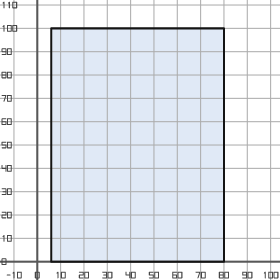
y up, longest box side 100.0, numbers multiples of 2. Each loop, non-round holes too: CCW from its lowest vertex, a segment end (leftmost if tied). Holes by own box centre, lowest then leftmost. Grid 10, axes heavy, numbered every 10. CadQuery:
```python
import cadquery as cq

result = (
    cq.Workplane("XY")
    .moveTo(6.0, 0.0)
    .lineTo(80.0, 0.0)
    .lineTo(80.0, 100.0)
    .lineTo(6.0, 100.0)
    .close()
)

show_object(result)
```